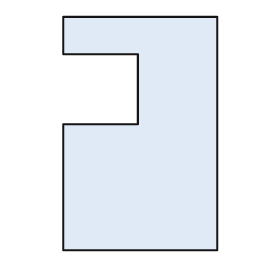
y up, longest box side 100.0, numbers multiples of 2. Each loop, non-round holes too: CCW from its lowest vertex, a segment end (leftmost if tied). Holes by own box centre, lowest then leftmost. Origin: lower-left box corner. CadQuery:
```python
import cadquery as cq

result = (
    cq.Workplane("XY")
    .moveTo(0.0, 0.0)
    .lineTo(66.0, 0.0)
    .lineTo(66.0, 100.0)
    .lineTo(0.0, 100.0)
    .lineTo(0.0, 84.0)
    .lineTo(32.0, 84.0)
    .lineTo(32.0, 54.0)
    .lineTo(0.0, 54.0)
    .close()
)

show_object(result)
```